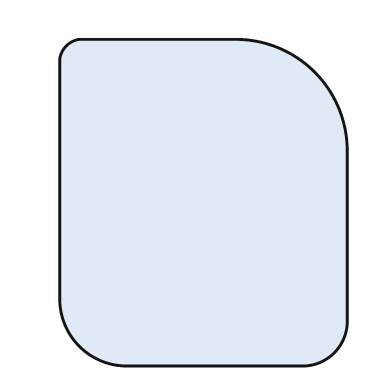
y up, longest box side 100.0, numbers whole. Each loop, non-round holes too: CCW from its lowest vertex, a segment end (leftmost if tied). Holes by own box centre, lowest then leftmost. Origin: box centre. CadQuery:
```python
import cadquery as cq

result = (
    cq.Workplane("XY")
    .moveTo(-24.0, -50.0)
    .lineTo(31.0, -50.0)
    .threePointArc((40.0, -46.0), (44.0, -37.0))
    .lineTo(44.0, 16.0)
    .threePointArc((34.0, 40.0), (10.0, 50.0))
    .lineTo(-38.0, 50.0)
    .threePointArc((-42.0, 48.0), (-44.0, 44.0))
    .lineTo(-44.0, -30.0)
    .threePointArc((-38.0, -44.0), (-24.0, -50.0))
    .close()
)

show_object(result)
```